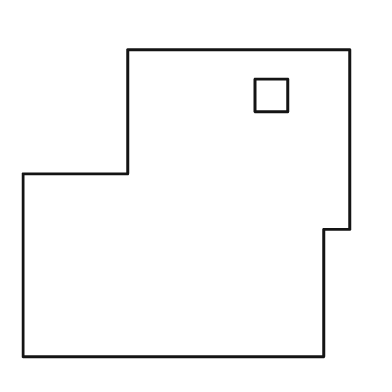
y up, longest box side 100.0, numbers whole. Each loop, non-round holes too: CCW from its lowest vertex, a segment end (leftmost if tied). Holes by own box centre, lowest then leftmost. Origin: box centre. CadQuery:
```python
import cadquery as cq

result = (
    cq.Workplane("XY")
    .moveTo(-50.0, -47.0)
    .lineTo(42.0, -47.0)
    .lineTo(42.0, -8.0)
    .lineTo(50.0, -8.0)
    .lineTo(50.0, 47.0)
    .lineTo(-18.0, 47.0)
    .lineTo(-18.0, 9.0)
    .lineTo(-50.0, 9.0)
    .close()
    .moveTo(21.0, 28.0)
    .lineTo(31.0, 28.0)
    .lineTo(31.0, 38.0)
    .lineTo(21.0, 38.0)
    .close()
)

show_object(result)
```